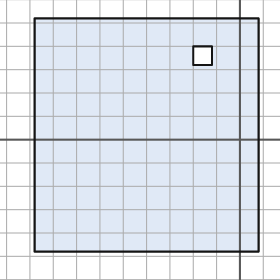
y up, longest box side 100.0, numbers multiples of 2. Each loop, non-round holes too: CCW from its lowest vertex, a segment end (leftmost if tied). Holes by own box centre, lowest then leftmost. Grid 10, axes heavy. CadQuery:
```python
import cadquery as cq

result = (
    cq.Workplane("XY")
    .moveTo(-88.0, -48.0)
    .lineTo(8.0, -48.0)
    .lineTo(8.0, 52.0)
    .lineTo(-88.0, 52.0)
    .close()
    .moveTo(-20.0, 32.0)
    .lineTo(-12.0, 32.0)
    .lineTo(-12.0, 40.0)
    .lineTo(-20.0, 40.0)
    .close()
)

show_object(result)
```